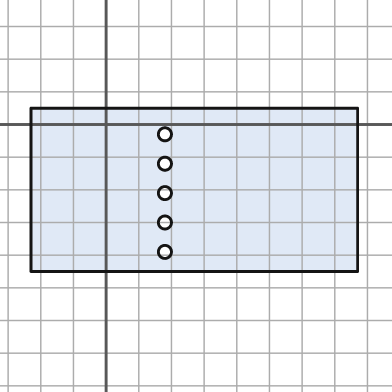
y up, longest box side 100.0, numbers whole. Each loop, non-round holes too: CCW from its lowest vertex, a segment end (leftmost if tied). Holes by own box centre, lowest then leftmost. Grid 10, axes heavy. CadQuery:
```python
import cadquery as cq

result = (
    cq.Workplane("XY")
    .moveTo(-23.0, -45.0)
    .lineTo(77.0, -45.0)
    .lineTo(77.0, 5.0)
    .lineTo(-23.0, 5.0)
    .close()
    .moveTo(18.0, -39.0)
    .circle(2.0)
    .moveTo(18.0, -30.0)
    .circle(2.0)
    .moveTo(18.0, -21.0)
    .circle(2.0)
    .moveTo(18.0, -12.0)
    .circle(2.0)
    .moveTo(18.0, -3.0)
    .circle(2.0)
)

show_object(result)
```